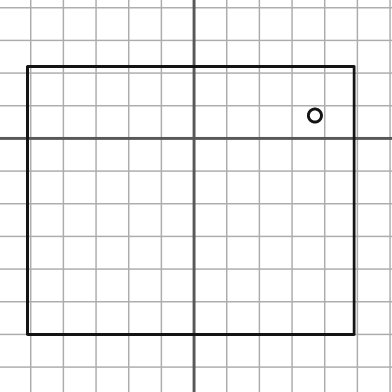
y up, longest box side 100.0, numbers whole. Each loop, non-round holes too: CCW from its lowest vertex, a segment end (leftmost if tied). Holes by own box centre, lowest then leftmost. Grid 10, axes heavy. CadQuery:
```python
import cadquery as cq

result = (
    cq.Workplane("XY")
    .moveTo(-51.0, -60.0)
    .lineTo(49.0, -60.0)
    .lineTo(49.0, 22.0)
    .lineTo(-51.0, 22.0)
    .close()
    .moveTo(37.0, 7.0)
    .circle(2.0)
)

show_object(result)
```